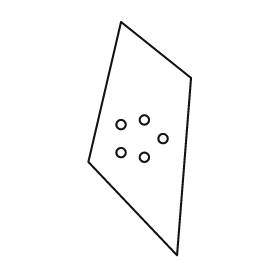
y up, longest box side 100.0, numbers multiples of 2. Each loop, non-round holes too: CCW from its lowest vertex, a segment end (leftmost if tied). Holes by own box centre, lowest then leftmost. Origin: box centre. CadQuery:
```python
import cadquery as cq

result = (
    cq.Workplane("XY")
    .moveTo(16.0, -50.0)
    .lineTo(22.0, 26.0)
    .lineTo(-8.0, 50.0)
    .lineTo(-22.0, -10.0)
    .close()
    .moveTo(2.0, -8.0)
    .circle(2.0)
    .moveTo(-8.0, -6.0)
    .circle(2.0)
    .moveTo(10.0, 0.0)
    .circle(2.0)
    .moveTo(-8.0, 6.0)
    .circle(2.0)
    .moveTo(2.0, 8.0)
    .circle(2.0)
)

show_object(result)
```